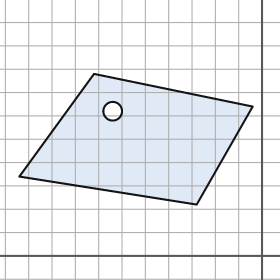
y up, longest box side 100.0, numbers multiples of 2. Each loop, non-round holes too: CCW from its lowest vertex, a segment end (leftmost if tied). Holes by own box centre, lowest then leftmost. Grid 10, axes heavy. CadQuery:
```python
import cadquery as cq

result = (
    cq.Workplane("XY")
    .moveTo(-28.0, 22.0)
    .lineTo(-4.0, 64.0)
    .lineTo(-72.0, 78.0)
    .lineTo(-104.0, 34.0)
    .close()
    .moveTo(-64.0, 62.0)
    .circle(4.0)
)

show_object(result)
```